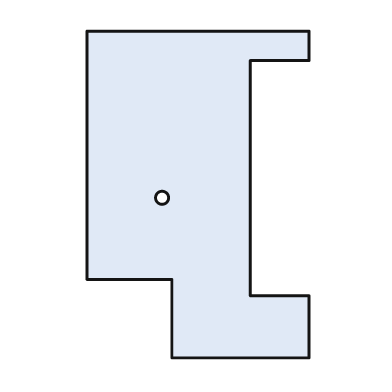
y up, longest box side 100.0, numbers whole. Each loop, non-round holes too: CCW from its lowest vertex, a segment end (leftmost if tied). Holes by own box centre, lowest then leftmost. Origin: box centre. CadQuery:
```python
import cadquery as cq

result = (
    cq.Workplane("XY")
    .moveTo(-8.0, -50.0)
    .lineTo(34.0, -50.0)
    .lineTo(34.0, -31.0)
    .lineTo(16.0, -31.0)
    .lineTo(16.0, 41.0)
    .lineTo(34.0, 41.0)
    .lineTo(34.0, 50.0)
    .lineTo(-34.0, 50.0)
    .lineTo(-34.0, -26.0)
    .lineTo(-8.0, -26.0)
    .close()
    .moveTo(-11.0, -1.0)
    .circle(2.0)
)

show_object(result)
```